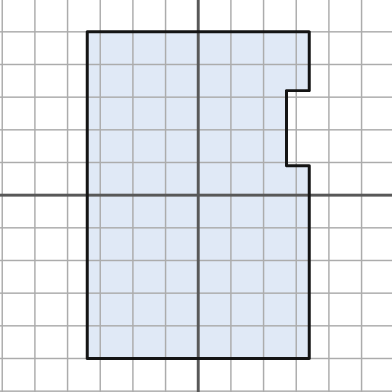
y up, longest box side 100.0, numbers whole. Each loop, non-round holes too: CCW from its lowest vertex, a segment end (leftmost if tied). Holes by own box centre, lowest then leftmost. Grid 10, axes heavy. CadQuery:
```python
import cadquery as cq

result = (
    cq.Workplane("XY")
    .moveTo(-34.0, -50.0)
    .lineTo(34.0, -50.0)
    .lineTo(34.0, 9.0)
    .lineTo(27.0, 9.0)
    .lineTo(27.0, 32.0)
    .lineTo(34.0, 32.0)
    .lineTo(34.0, 50.0)
    .lineTo(-34.0, 50.0)
    .close()
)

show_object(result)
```